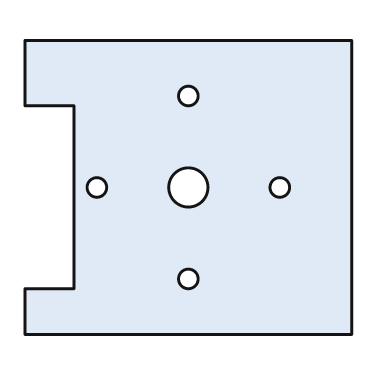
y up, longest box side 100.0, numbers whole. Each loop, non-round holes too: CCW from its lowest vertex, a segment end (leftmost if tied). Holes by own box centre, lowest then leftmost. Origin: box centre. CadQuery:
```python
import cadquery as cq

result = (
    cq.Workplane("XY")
    .moveTo(-50.0, -45.0)
    .lineTo(50.0, -45.0)
    .lineTo(50.0, 45.0)
    .lineTo(-50.0, 45.0)
    .lineTo(-50.0, 25.0)
    .lineTo(-35.0, 25.0)
    .lineTo(-35.0, -31.0)
    .lineTo(-50.0, -31.0)
    .close()
    .moveTo(0.0, -28.0)
    .circle(3.0)
    .moveTo(-28.0, 0.0)
    .circle(3.0)
    .moveTo(0.0, 0.0)
    .circle(6.0)
    .moveTo(28.0, 0.0)
    .circle(3.0)
    .moveTo(0.0, 28.0)
    .circle(3.0)
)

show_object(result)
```